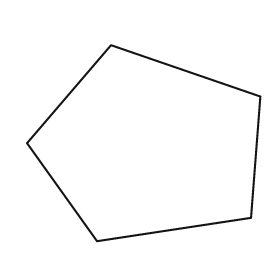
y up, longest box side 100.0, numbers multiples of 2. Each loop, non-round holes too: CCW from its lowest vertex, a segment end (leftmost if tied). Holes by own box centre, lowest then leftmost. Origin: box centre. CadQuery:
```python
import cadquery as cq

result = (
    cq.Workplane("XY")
    .moveTo(-20.0, -42.0)
    .lineTo(46.0, -32.0)
    .lineTo(50.0, 20.0)
    .lineTo(-14.0, 42.0)
    .lineTo(-50.0, 0.0)
    .close()
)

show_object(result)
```